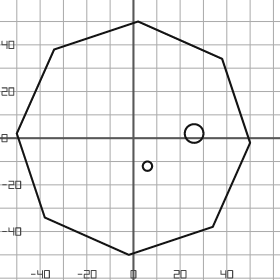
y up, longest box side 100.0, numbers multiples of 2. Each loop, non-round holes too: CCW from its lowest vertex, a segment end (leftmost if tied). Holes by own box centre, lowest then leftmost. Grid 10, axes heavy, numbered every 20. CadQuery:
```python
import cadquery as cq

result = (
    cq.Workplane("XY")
    .moveTo(-2.0, -50.0)
    .lineTo(34.0, -38.0)
    .lineTo(50.0, -2.0)
    .lineTo(38.0, 34.0)
    .lineTo(2.0, 50.0)
    .lineTo(-34.0, 38.0)
    .lineTo(-50.0, 2.0)
    .lineTo(-38.0, -34.0)
    .close()
    .moveTo(6.0, -12.0)
    .circle(2.0)
    .moveTo(26.0, 2.0)
    .circle(4.0)
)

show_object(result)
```